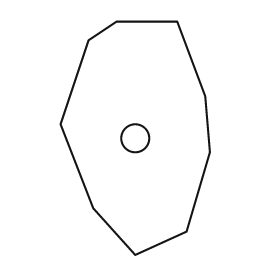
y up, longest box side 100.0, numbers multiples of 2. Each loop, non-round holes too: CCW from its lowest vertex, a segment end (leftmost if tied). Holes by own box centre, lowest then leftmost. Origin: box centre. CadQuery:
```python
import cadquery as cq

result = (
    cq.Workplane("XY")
    .moveTo(0.0, -50.0)
    .lineTo(22.0, -40.0)
    .lineTo(32.0, -6.0)
    .lineTo(30.0, 18.0)
    .lineTo(18.0, 50.0)
    .lineTo(-8.0, 50.0)
    .lineTo(-20.0, 42.0)
    .lineTo(-32.0, 6.0)
    .lineTo(-18.0, -30.0)
    .close()
    .moveTo(0.0, 0.0)
    .circle(6.0)
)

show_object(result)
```